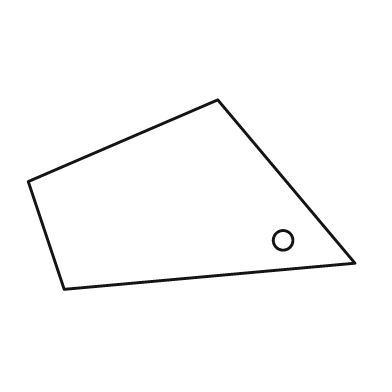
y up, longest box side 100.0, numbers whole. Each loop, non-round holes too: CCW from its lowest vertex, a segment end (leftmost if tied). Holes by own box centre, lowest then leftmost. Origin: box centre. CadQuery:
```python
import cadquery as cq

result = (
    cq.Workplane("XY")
    .moveTo(-39.0, -29.0)
    .lineTo(50.0, -21.0)
    .lineTo(8.0, 29.0)
    .lineTo(-50.0, 4.0)
    .close()
    .moveTo(28.0, -14.0)
    .circle(3.0)
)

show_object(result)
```